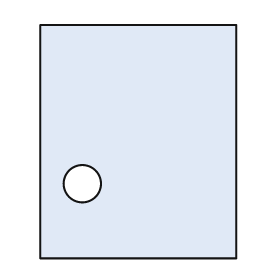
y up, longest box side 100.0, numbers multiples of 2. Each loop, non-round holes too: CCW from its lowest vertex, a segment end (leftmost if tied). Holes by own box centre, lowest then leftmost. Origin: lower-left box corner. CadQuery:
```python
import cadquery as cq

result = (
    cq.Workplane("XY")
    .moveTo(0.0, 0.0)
    .lineTo(84.0, 0.0)
    .lineTo(84.0, 100.0)
    .lineTo(0.0, 100.0)
    .close()
    .moveTo(18.0, 32.0)
    .circle(8.0)
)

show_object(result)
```